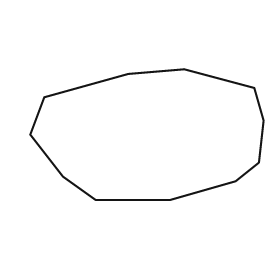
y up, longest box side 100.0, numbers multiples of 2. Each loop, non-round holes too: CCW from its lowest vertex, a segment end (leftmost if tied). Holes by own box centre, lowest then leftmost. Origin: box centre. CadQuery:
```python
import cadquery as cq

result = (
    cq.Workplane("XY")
    .moveTo(-22.0, -28.0)
    .lineTo(10.0, -28.0)
    .lineTo(38.0, -20.0)
    .lineTo(48.0, -12.0)
    .lineTo(50.0, 6.0)
    .lineTo(46.0, 20.0)
    .lineTo(16.0, 28.0)
    .lineTo(-8.0, 26.0)
    .lineTo(-44.0, 16.0)
    .lineTo(-50.0, 0.0)
    .lineTo(-36.0, -18.0)
    .close()
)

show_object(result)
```